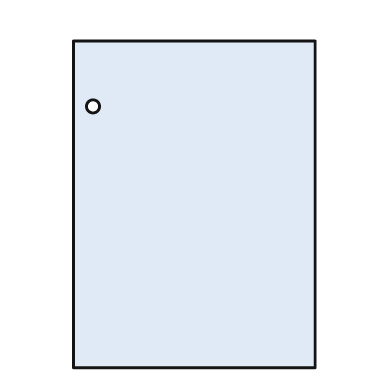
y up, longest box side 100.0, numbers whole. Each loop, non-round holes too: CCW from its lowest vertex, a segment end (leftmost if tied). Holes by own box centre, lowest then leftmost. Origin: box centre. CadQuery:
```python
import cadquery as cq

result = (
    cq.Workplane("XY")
    .moveTo(-37.0, -50.0)
    .lineTo(37.0, -50.0)
    .lineTo(37.0, 50.0)
    .lineTo(-37.0, 50.0)
    .close()
    .moveTo(-31.0, 30.0)
    .circle(2.0)
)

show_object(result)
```